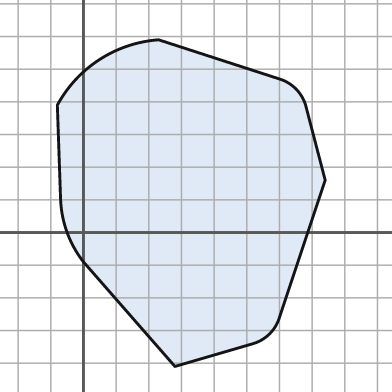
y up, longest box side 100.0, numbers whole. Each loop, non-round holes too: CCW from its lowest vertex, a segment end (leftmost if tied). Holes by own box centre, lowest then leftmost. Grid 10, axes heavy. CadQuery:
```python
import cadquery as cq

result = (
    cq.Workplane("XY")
    .moveTo(28.0, -41.0)
    .lineTo(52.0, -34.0)
    .threePointArc((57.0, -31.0), (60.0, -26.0))
    .lineTo(74.0, 16.0)
    .lineTo(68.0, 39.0)
    .threePointArc((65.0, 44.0), (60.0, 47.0))
    .lineTo(23.0, 59.0)
    .threePointArc((5.0, 53.0), (-8.0, 39.0))
    .lineTo(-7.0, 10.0)
    .threePointArc((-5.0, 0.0), (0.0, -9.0))
    .close()
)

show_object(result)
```